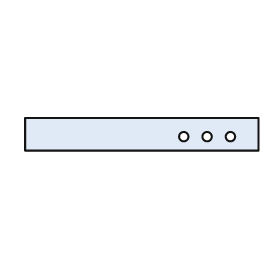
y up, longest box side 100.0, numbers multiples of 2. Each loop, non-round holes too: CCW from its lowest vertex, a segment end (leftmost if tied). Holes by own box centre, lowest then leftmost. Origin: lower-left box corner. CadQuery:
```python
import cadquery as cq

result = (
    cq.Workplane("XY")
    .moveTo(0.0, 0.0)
    .lineTo(100.0, 0.0)
    .lineTo(100.0, 14.0)
    .lineTo(0.0, 14.0)
    .close()
    .moveTo(68.0, 6.0)
    .circle(2.0)
    .moveTo(78.0, 6.0)
    .circle(2.0)
    .moveTo(88.0, 6.0)
    .circle(2.0)
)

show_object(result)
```